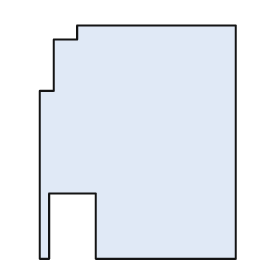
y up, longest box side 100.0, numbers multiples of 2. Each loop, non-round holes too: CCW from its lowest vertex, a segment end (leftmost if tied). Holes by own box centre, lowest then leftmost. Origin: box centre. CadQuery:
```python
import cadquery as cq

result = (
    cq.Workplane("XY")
    .moveTo(-42.0, -50.0)
    .lineTo(-38.0, -50.0)
    .lineTo(-38.0, -22.0)
    .lineTo(-18.0, -22.0)
    .lineTo(-18.0, -50.0)
    .lineTo(42.0, -50.0)
    .lineTo(42.0, 50.0)
    .lineTo(-26.0, 50.0)
    .lineTo(-26.0, 44.0)
    .lineTo(-36.0, 44.0)
    .lineTo(-36.0, 22.0)
    .lineTo(-42.0, 22.0)
    .close()
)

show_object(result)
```